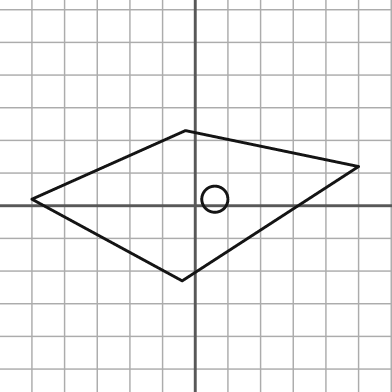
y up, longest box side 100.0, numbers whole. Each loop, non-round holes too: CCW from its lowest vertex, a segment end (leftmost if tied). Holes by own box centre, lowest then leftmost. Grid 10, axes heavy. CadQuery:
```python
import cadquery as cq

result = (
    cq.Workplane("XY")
    .moveTo(-4.0, -23.0)
    .lineTo(50.0, 12.0)
    .lineTo(-3.0, 23.0)
    .lineTo(-50.0, 2.0)
    .close()
    .moveTo(6.0, 2.0)
    .circle(4.0)
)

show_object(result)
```